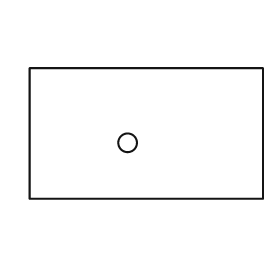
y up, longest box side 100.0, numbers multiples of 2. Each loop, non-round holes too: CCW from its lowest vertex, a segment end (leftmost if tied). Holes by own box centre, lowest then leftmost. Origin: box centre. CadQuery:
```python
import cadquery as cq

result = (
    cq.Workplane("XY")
    .moveTo(-50.0, -28.0)
    .lineTo(50.0, -28.0)
    .lineTo(50.0, 28.0)
    .lineTo(-50.0, 28.0)
    .close()
    .moveTo(-8.0, -4.0)
    .circle(4.0)
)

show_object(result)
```